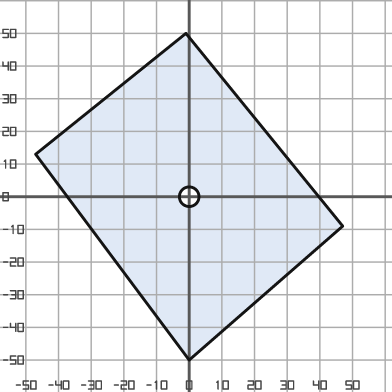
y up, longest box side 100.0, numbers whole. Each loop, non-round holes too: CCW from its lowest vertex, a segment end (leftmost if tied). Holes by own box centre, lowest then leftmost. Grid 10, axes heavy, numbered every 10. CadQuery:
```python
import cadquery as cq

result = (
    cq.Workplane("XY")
    .moveTo(0.0, -50.0)
    .lineTo(47.0, -9.0)
    .lineTo(-1.0, 50.0)
    .lineTo(-47.0, 13.0)
    .close()
    .moveTo(0.0, 0.0)
    .circle(3.0)
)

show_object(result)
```